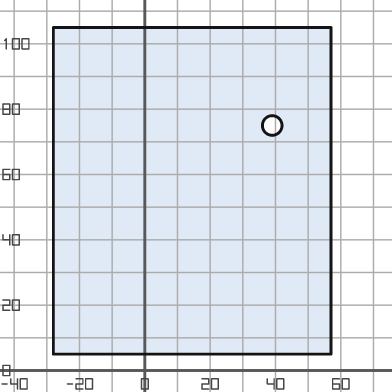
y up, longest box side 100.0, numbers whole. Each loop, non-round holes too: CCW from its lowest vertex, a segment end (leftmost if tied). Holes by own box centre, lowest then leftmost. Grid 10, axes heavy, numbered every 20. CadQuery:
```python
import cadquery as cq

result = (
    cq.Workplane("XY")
    .moveTo(-28.0, 5.0)
    .lineTo(57.0, 5.0)
    .lineTo(57.0, 105.0)
    .lineTo(-28.0, 105.0)
    .close()
    .moveTo(39.0, 75.0)
    .circle(3.0)
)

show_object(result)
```